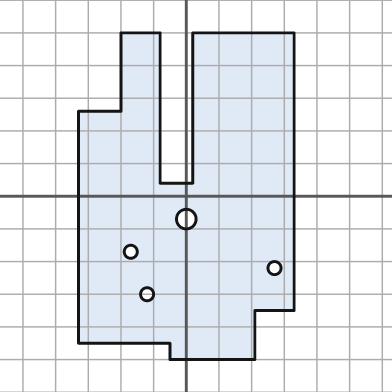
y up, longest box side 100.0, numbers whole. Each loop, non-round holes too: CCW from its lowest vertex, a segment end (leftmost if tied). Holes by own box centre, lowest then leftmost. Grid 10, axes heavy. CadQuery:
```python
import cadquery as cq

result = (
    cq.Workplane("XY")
    .moveTo(-5.0, -50.0)
    .lineTo(21.0, -50.0)
    .lineTo(21.0, -35.0)
    .lineTo(33.0, -35.0)
    .lineTo(33.0, 50.0)
    .lineTo(2.0, 50.0)
    .lineTo(2.0, 4.0)
    .lineTo(-8.0, 4.0)
    .lineTo(-8.0, 50.0)
    .lineTo(-20.0, 50.0)
    .lineTo(-20.0, 26.0)
    .lineTo(-33.0, 26.0)
    .lineTo(-33.0, -45.0)
    .lineTo(-5.0, -45.0)
    .close()
    .moveTo(-12.0, -30.0)
    .circle(2.0)
    .moveTo(27.0, -22.0)
    .circle(2.0)
    .moveTo(-17.0, -17.0)
    .circle(2.0)
    .moveTo(0.0, -7.0)
    .circle(3.0)
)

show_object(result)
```